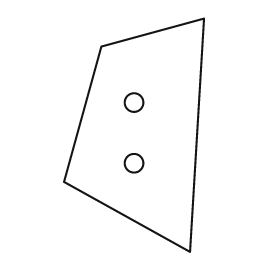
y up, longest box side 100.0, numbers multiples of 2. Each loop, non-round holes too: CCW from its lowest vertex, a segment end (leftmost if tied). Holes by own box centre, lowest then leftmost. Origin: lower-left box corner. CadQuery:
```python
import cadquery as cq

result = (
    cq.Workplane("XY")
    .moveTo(54.0, 0.0)
    .lineTo(60.0, 100.0)
    .lineTo(16.0, 88.0)
    .lineTo(0.0, 30.0)
    .close()
    .moveTo(30.0, 38.0)
    .circle(4.0)
    .moveTo(30.0, 64.0)
    .circle(4.0)
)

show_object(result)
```